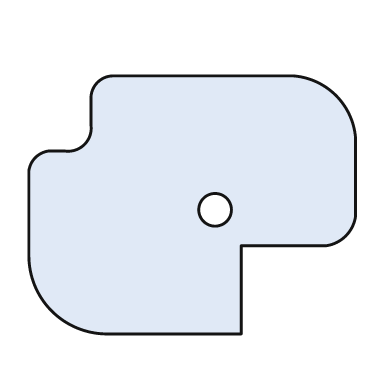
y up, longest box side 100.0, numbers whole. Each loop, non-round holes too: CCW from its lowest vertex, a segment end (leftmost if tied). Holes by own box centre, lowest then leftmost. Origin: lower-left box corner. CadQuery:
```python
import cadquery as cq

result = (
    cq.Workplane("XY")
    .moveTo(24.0, 0.0)
    .lineTo(65.0, 0.0)
    .lineTo(65.0, 27.0)
    .lineTo(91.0, 27.0)
    .threePointArc((97.0, 30.0), (100.0, 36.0))
    .lineTo(100.0, 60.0)
    .threePointArc((94.0, 73.0), (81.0, 79.0))
    .lineTo(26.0, 79.0)
    .threePointArc((21.0, 77.0), (19.0, 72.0))
    .lineTo(19.0, 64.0)
    .threePointArc((17.0, 58.0), (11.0, 56.0))
    .lineTo(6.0, 56.0)
    .threePointArc((2.0, 54.0), (0.0, 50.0))
    .lineTo(0.0, 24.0)
    .threePointArc((7.0, 7.0), (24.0, 0.0))
    .close()
    .moveTo(57.0, 38.0)
    .circle(5.0)
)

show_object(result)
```